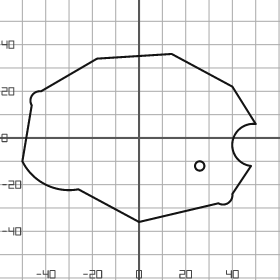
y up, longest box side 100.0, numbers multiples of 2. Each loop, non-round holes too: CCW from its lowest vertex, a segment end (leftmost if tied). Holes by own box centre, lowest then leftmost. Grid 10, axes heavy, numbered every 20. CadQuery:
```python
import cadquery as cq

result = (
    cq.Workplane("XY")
    .moveTo(0.0, -36.0)
    .lineTo(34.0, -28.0)
    .threePointArc((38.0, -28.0), (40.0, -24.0))
    .lineTo(48.0, -12.0)
    .threePointArc((40.0, -2.0), (50.0, 6.0))
    .lineTo(40.0, 22.0)
    .lineTo(14.0, 36.0)
    .lineTo(-18.0, 34.0)
    .lineTo(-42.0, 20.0)
    .threePointArc((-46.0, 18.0), (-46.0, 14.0))
    .lineTo(-50.0, -10.0)
    .threePointArc((-40.0, -20.0), (-26.0, -22.0))
    .close()
    .moveTo(26.0, -12.0)
    .circle(2.0)
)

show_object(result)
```